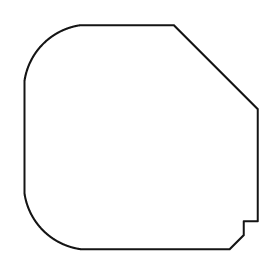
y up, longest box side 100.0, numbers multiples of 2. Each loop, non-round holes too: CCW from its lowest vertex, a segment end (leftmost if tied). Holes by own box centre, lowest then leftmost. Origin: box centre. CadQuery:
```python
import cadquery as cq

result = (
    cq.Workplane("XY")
    .moveTo(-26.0, -48.0)
    .lineTo(38.0, -48.0)
    .lineTo(44.0, -42.0)
    .lineTo(44.0, -36.0)
    .lineTo(50.0, -36.0)
    .lineTo(50.0, 12.0)
    .lineTo(14.0, 48.0)
    .lineTo(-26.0, 48.0)
    .threePointArc((-42.0, 40.0), (-50.0, 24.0))
    .lineTo(-50.0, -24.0)
    .threePointArc((-42.0, -40.0), (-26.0, -48.0))
    .close()
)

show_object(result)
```